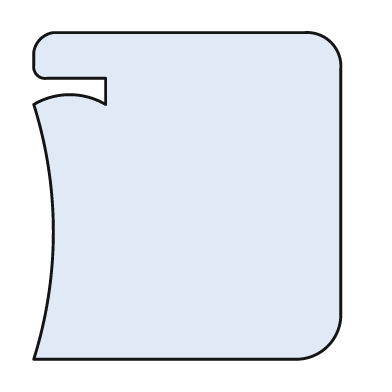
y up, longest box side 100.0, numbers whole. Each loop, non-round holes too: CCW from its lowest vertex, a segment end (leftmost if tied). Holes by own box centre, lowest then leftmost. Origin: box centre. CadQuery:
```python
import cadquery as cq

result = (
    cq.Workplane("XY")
    .moveTo(-47.0, -50.0)
    .lineTo(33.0, -50.0)
    .threePointArc((43.0, -46.0), (47.0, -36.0))
    .lineTo(47.0, 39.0)
    .threePointArc((44.0, 47.0), (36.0, 50.0))
    .lineTo(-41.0, 50.0)
    .threePointArc((-45.0, 48.0), (-47.0, 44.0))
    .lineTo(-47.0, 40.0)
    .threePointArc((-46.0, 37.0), (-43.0, 36.0))
    .lineTo(-25.0, 36.0)
    .lineTo(-25.0, 28.0)
    .threePointArc((-36.0, 31.0), (-47.0, 28.0))
    .threePointArc((-41.0, -11.0), (-47.0, -50.0))
    .close()
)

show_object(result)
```